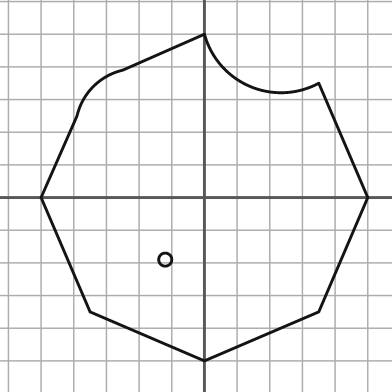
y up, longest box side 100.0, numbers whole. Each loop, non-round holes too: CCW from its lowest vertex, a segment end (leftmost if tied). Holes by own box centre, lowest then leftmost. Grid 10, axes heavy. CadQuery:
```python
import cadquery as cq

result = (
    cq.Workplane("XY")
    .moveTo(0.0, -50.0)
    .lineTo(35.0, -35.0)
    .lineTo(50.0, 0.0)
    .lineTo(35.0, 35.0)
    .threePointArc((14.0, 34.0), (0.0, 50.0))
    .lineTo(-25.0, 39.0)
    .threePointArc((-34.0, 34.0), (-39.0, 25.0))
    .lineTo(-50.0, 0.0)
    .lineTo(-35.0, -35.0)
    .close()
    .moveTo(-12.0, -19.0)
    .circle(2.0)
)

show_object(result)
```